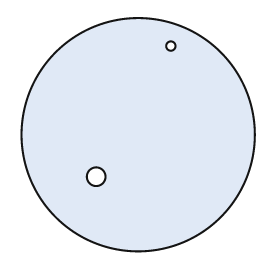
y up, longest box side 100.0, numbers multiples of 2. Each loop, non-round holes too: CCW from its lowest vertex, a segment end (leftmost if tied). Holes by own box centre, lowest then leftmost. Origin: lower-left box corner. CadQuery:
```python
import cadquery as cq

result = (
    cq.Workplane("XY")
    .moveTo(50.0, 50.0)
    .circle(50.0)
    .moveTo(32.0, 32.0)
    .circle(4.0)
    .moveTo(64.0, 88.0)
    .circle(2.0)
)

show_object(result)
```